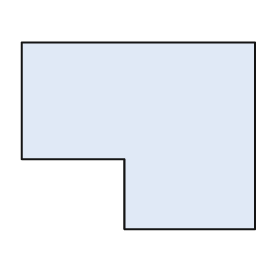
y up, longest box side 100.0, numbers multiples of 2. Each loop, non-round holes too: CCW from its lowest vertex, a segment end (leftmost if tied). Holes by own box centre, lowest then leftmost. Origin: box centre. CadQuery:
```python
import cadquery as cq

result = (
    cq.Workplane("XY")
    .moveTo(-6.0, -40.0)
    .lineTo(50.0, -40.0)
    .lineTo(50.0, 40.0)
    .lineTo(-50.0, 40.0)
    .lineTo(-50.0, -10.0)
    .lineTo(-6.0, -10.0)
    .close()
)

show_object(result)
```